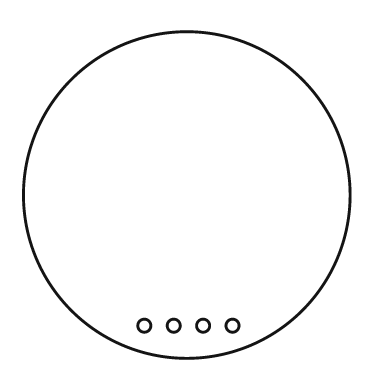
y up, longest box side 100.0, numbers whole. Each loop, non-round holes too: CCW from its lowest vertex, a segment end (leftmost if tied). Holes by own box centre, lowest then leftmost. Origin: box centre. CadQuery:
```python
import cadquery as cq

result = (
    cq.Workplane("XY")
    .moveTo(0.0, 0.0)
    .circle(50.0)
    .moveTo(-13.0, -40.0)
    .circle(2.0)
    .moveTo(-4.0, -40.0)
    .circle(2.0)
    .moveTo(5.0, -40.0)
    .circle(2.0)
    .moveTo(14.0, -40.0)
    .circle(2.0)
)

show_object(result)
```